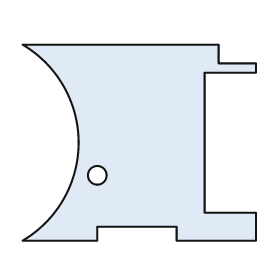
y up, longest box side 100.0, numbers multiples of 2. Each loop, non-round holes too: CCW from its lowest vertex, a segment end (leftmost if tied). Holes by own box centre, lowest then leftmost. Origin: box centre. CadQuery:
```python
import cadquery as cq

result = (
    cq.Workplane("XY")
    .moveTo(-50.0, -42.0)
    .lineTo(-18.0, -42.0)
    .lineTo(-18.0, -36.0)
    .lineTo(16.0, -36.0)
    .lineTo(16.0, -42.0)
    .lineTo(50.0, -42.0)
    .lineTo(50.0, -30.0)
    .lineTo(28.0, -30.0)
    .lineTo(28.0, 30.0)
    .lineTo(50.0, 30.0)
    .lineTo(50.0, 34.0)
    .lineTo(34.0, 34.0)
    .lineTo(34.0, 42.0)
    .lineTo(-50.0, 42.0)
    .threePointArc((-26.0, 0.0), (-50.0, -42.0))
    .close()
    .moveTo(-18.0, -14.0)
    .circle(4.0)
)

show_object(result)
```